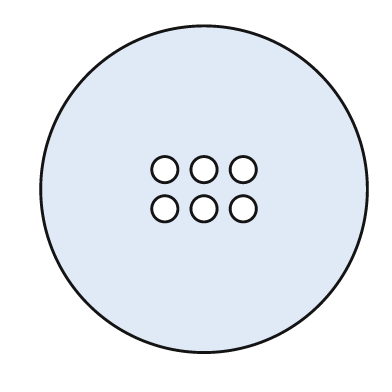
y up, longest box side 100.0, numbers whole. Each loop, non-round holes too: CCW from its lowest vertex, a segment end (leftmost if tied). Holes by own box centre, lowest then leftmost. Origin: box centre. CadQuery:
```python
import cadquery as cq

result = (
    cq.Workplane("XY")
    .moveTo(0.0, 0.0)
    .circle(50.0)
    .moveTo(-12.0, -6.0)
    .circle(4.0)
    .moveTo(0.0, -6.0)
    .circle(4.0)
    .moveTo(12.0, -6.0)
    .circle(4.0)
    .moveTo(-12.0, 6.0)
    .circle(4.0)
    .moveTo(0.0, 6.0)
    .circle(4.0)
    .moveTo(12.0, 6.0)
    .circle(4.0)
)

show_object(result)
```